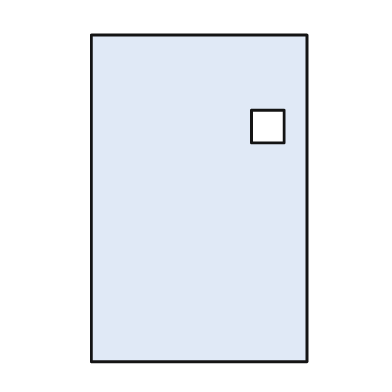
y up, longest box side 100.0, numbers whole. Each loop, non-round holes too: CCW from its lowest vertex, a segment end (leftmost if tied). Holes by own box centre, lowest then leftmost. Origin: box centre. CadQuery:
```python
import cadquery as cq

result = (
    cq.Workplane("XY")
    .moveTo(-33.0, -50.0)
    .lineTo(33.0, -50.0)
    .lineTo(33.0, 50.0)
    .lineTo(-33.0, 50.0)
    .close()
    .moveTo(16.0, 17.0)
    .lineTo(26.0, 17.0)
    .lineTo(26.0, 27.0)
    .lineTo(16.0, 27.0)
    .close()
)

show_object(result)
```